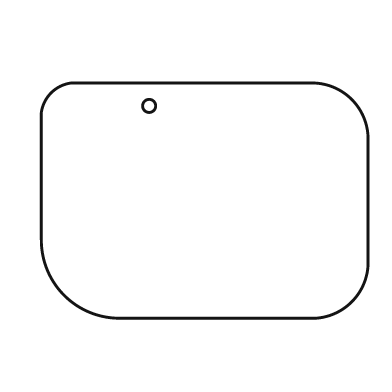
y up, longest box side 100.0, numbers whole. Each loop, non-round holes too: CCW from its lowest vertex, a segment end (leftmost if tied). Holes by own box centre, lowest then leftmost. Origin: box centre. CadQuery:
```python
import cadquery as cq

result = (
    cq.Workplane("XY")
    .moveTo(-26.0, -36.0)
    .lineTo(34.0, -36.0)
    .threePointArc((45.0, -31.0), (50.0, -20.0))
    .lineTo(50.0, 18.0)
    .threePointArc((45.0, 31.0), (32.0, 36.0))
    .lineTo(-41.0, 36.0)
    .threePointArc((-47.0, 33.0), (-50.0, 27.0))
    .lineTo(-50.0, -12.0)
    .threePointArc((-43.0, -29.0), (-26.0, -36.0))
    .close()
    .moveTo(-17.0, 29.0)
    .circle(2.0)
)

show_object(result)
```